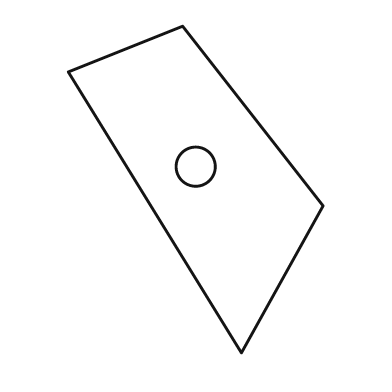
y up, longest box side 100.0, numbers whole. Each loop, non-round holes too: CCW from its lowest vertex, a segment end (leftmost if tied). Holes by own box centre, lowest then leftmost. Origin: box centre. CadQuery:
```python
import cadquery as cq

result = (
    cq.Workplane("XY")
    .moveTo(14.0, -50.0)
    .lineTo(39.0, -5.0)
    .lineTo(-4.0, 50.0)
    .lineTo(-39.0, 36.0)
    .close()
    .moveTo(0.0, 7.0)
    .circle(6.0)
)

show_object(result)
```